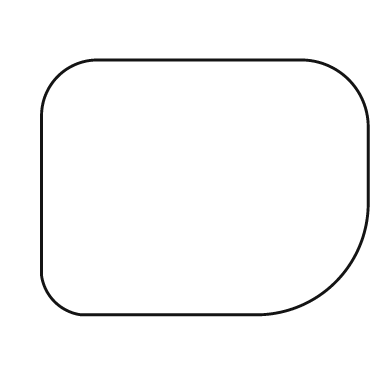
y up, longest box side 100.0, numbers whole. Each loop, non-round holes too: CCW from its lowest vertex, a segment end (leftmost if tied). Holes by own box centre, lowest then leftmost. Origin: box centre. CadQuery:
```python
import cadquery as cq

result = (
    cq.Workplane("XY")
    .moveTo(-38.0, -39.0)
    .lineTo(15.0, -39.0)
    .threePointArc((40.0, -29.0), (50.0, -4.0))
    .lineTo(50.0, 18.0)
    .threePointArc((44.0, 33.0), (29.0, 39.0))
    .lineTo(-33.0, 39.0)
    .threePointArc((-45.0, 34.0), (-50.0, 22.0))
    .lineTo(-50.0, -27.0)
    .threePointArc((-46.0, -35.0), (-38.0, -39.0))
    .close()
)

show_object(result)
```